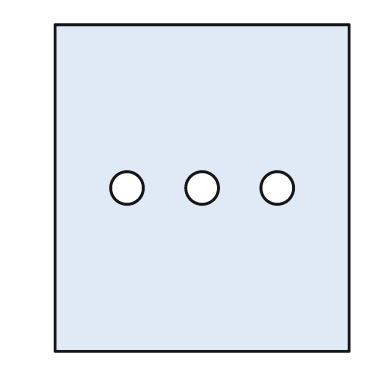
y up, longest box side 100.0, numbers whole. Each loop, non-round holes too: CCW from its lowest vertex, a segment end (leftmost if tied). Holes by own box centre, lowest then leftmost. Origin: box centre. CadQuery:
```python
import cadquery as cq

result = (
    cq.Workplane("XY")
    .moveTo(-45.0, -50.0)
    .lineTo(45.0, -50.0)
    .lineTo(45.0, 50.0)
    .lineTo(-45.0, 50.0)
    .close()
    .moveTo(-23.0, 0.0)
    .circle(5.0)
    .moveTo(0.0, 0.0)
    .circle(5.0)
    .moveTo(23.0, 0.0)
    .circle(5.0)
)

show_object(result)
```